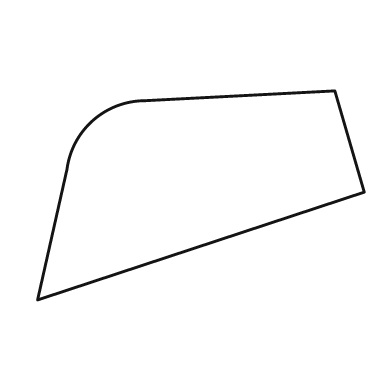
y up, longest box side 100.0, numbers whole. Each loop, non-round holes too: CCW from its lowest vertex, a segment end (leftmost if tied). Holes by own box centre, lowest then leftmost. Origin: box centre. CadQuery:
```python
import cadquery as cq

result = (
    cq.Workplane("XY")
    .moveTo(-50.0, -32.0)
    .lineTo(50.0, 1.0)
    .lineTo(41.0, 32.0)
    .lineTo(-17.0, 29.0)
    .threePointArc((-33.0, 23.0), (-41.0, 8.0))
    .close()
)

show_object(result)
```